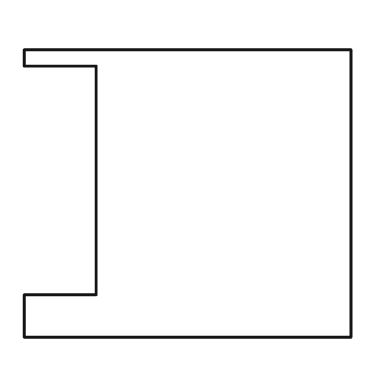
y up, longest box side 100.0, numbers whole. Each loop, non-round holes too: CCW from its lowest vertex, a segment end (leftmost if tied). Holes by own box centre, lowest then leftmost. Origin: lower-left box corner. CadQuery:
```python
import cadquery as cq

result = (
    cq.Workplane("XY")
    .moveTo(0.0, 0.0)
    .lineTo(100.0, 0.0)
    .lineTo(100.0, 88.0)
    .lineTo(0.0, 88.0)
    .lineTo(0.0, 83.0)
    .lineTo(22.0, 83.0)
    .lineTo(22.0, 13.0)
    .lineTo(0.0, 13.0)
    .close()
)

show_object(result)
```